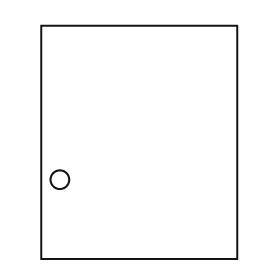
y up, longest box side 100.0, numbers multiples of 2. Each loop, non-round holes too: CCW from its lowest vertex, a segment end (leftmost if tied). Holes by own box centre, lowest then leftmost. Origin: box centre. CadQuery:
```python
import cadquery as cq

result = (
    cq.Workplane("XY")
    .moveTo(-42.0, -50.0)
    .lineTo(42.0, -50.0)
    .lineTo(42.0, 50.0)
    .lineTo(-42.0, 50.0)
    .close()
    .moveTo(-34.0, -16.0)
    .circle(4.0)
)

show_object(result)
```